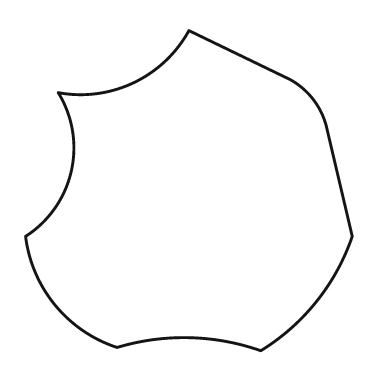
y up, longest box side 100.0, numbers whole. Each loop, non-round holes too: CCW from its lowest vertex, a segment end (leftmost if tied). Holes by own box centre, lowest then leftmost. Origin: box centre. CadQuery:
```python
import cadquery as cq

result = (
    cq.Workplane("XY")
    .moveTo(22.0, -49.0)
    .threePointArc((39.0, -34.0), (50.0, -14.0))
    .lineTo(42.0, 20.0)
    .threePointArc((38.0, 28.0), (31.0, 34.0))
    .lineTo(0.0, 49.0)
    .threePointArc((-17.0, 33.0), (-40.0, 30.0))
    .threePointArc((-36.0, 6.0), (-50.0, -14.0))
    .threePointArc((-41.0, -35.0), (-22.0, -48.0))
    .threePointArc((0.0, -45.0), (22.0, -49.0))
    .close()
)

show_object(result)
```